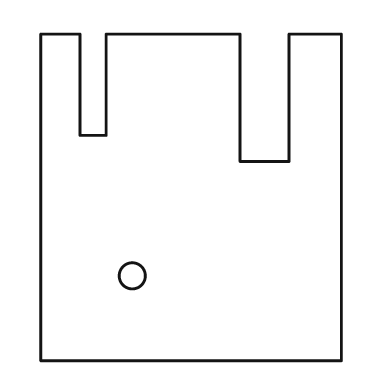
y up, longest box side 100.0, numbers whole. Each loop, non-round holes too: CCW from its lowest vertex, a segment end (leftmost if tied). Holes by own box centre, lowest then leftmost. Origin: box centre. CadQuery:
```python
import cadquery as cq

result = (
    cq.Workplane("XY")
    .moveTo(-46.0, -50.0)
    .lineTo(46.0, -50.0)
    .lineTo(46.0, 50.0)
    .lineTo(30.0, 50.0)
    .lineTo(30.0, 11.0)
    .lineTo(15.0, 11.0)
    .lineTo(15.0, 50.0)
    .lineTo(-26.0, 50.0)
    .lineTo(-26.0, 19.0)
    .lineTo(-34.0, 19.0)
    .lineTo(-34.0, 50.0)
    .lineTo(-46.0, 50.0)
    .close()
    .moveTo(-18.0, -24.0)
    .circle(4.0)
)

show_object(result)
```